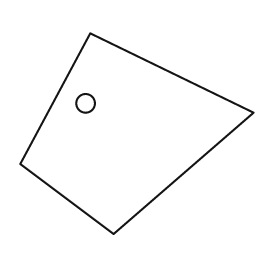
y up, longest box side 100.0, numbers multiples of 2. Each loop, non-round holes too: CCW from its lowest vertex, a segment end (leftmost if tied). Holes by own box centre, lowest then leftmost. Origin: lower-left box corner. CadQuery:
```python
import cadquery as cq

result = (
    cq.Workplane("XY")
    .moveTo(40.0, 0.0)
    .lineTo(100.0, 52.0)
    .lineTo(30.0, 86.0)
    .lineTo(0.0, 30.0)
    .close()
    .moveTo(28.0, 56.0)
    .circle(4.0)
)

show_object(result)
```